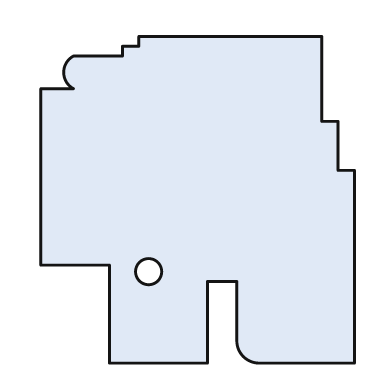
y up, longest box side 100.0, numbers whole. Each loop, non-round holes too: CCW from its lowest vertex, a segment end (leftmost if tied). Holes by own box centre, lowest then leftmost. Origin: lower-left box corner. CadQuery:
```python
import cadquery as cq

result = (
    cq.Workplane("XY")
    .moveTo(21.0, 0.0)
    .lineTo(51.0, 0.0)
    .lineTo(51.0, 25.0)
    .lineTo(60.0, 25.0)
    .lineTo(60.0, 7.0)
    .threePointArc((62.0, 2.0), (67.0, 0.0))
    .lineTo(96.0, 0.0)
    .lineTo(96.0, 59.0)
    .lineTo(91.0, 59.0)
    .lineTo(91.0, 74.0)
    .lineTo(86.0, 74.0)
    .lineTo(86.0, 100.0)
    .lineTo(30.0, 100.0)
    .lineTo(30.0, 97.0)
    .lineTo(25.0, 97.0)
    .lineTo(25.0, 94.0)
    .lineTo(10.0, 94.0)
    .threePointArc((7.0, 89.0), (10.0, 84.0))
    .lineTo(0.0, 84.0)
    .lineTo(0.0, 30.0)
    .lineTo(21.0, 30.0)
    .close()
    .moveTo(33.0, 28.0)
    .circle(4.0)
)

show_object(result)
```